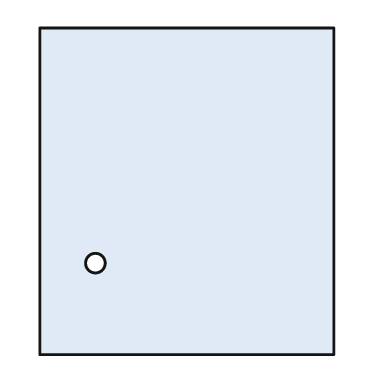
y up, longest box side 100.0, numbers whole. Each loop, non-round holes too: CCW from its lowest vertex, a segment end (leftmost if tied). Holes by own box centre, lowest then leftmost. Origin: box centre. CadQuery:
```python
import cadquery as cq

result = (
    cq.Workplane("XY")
    .moveTo(-45.0, -50.0)
    .lineTo(45.0, -50.0)
    .lineTo(45.0, 50.0)
    .lineTo(-45.0, 50.0)
    .close()
    .moveTo(-28.0, -22.0)
    .circle(3.0)
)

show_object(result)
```